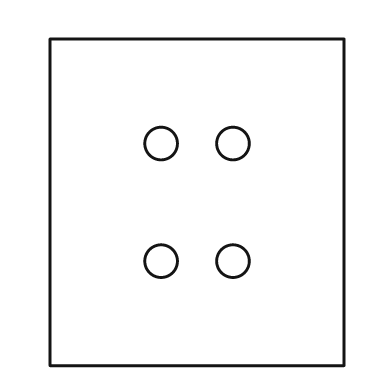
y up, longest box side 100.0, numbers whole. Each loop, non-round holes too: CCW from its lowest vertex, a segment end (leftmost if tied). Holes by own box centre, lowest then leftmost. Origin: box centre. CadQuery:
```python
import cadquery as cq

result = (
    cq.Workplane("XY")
    .moveTo(-45.0, -50.0)
    .lineTo(45.0, -50.0)
    .lineTo(45.0, 50.0)
    .lineTo(-45.0, 50.0)
    .close()
    .moveTo(-11.0, -18.0)
    .circle(5.0)
    .moveTo(11.0, -18.0)
    .circle(5.0)
    .moveTo(-11.0, 18.0)
    .circle(5.0)
    .moveTo(11.0, 18.0)
    .circle(5.0)
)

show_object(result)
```